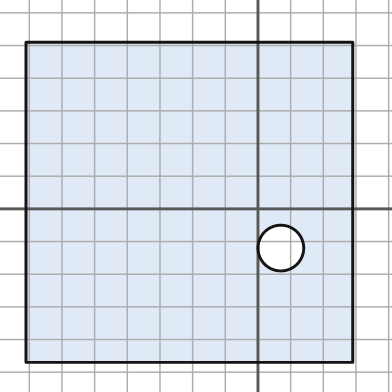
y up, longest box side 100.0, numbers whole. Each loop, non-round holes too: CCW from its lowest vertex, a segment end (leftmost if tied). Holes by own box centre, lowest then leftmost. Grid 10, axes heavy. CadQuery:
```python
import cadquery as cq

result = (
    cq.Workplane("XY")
    .moveTo(-71.0, -47.0)
    .lineTo(29.0, -47.0)
    .lineTo(29.0, 51.0)
    .lineTo(-71.0, 51.0)
    .close()
    .moveTo(7.0, -12.0)
    .circle(7.0)
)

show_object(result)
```